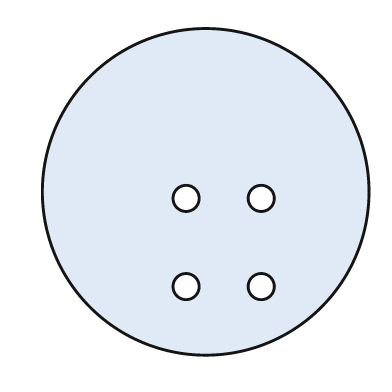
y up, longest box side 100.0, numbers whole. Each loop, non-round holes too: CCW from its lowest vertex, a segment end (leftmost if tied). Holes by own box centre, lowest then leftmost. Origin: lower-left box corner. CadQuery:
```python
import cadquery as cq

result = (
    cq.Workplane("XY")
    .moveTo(50.0, 50.0)
    .circle(50.0)
    .moveTo(44.0, 21.0)
    .circle(4.0)
    .moveTo(67.0, 21.0)
    .circle(4.0)
    .moveTo(44.0, 48.0)
    .circle(4.0)
    .moveTo(67.0, 48.0)
    .circle(4.0)
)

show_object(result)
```